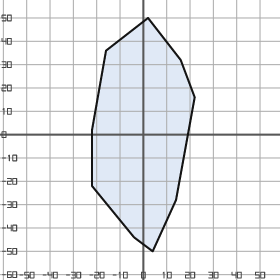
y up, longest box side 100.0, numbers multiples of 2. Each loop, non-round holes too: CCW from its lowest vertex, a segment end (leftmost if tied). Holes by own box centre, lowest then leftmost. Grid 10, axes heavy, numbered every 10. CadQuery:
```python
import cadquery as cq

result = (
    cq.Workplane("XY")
    .moveTo(4.0, -50.0)
    .lineTo(14.0, -28.0)
    .lineTo(22.0, 16.0)
    .lineTo(16.0, 32.0)
    .lineTo(2.0, 50.0)
    .lineTo(-16.0, 36.0)
    .lineTo(-22.0, 2.0)
    .lineTo(-22.0, -22.0)
    .lineTo(-4.0, -44.0)
    .close()
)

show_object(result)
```